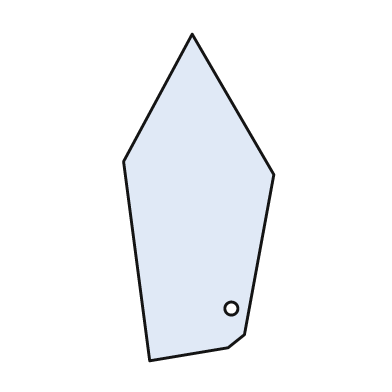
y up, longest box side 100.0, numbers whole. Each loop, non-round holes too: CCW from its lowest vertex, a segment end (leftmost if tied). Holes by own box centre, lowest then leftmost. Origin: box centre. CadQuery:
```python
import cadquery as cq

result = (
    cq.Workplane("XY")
    .moveTo(-15.0, -50.0)
    .lineTo(9.0, -46.0)
    .lineTo(14.0, -42.0)
    .lineTo(23.0, 7.0)
    .lineTo(-2.0, 50.0)
    .lineTo(-23.0, 11.0)
    .close()
    .moveTo(10.0, -34.0)
    .circle(2.0)
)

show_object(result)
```